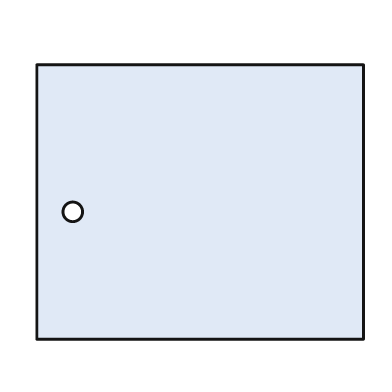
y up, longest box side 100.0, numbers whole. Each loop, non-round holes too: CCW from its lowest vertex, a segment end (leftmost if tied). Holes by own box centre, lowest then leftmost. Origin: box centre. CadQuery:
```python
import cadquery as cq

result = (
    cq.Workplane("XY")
    .moveTo(-50.0, -42.0)
    .lineTo(50.0, -42.0)
    .lineTo(50.0, 42.0)
    .lineTo(-50.0, 42.0)
    .close()
    .moveTo(-39.0, -3.0)
    .circle(3.0)
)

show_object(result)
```